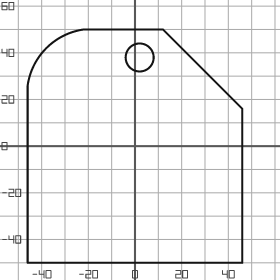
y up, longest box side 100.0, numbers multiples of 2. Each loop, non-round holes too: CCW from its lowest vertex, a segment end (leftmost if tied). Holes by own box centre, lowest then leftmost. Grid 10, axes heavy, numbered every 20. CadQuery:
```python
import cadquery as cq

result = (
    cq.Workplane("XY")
    .moveTo(-46.0, -50.0)
    .lineTo(46.0, -50.0)
    .lineTo(46.0, 16.0)
    .lineTo(12.0, 50.0)
    .lineTo(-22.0, 50.0)
    .threePointArc((-38.0, 42.0), (-46.0, 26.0))
    .close()
    .moveTo(2.0, 38.0)
    .circle(6.0)
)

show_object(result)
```